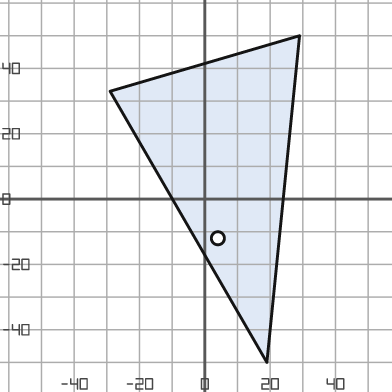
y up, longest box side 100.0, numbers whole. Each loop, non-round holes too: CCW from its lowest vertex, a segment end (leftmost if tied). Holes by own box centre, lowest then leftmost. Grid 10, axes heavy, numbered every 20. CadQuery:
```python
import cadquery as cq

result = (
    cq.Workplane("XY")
    .moveTo(19.0, -50.0)
    .lineTo(29.0, 50.0)
    .lineTo(-29.0, 33.0)
    .close()
    .moveTo(4.0, -12.0)
    .circle(2.0)
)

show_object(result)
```